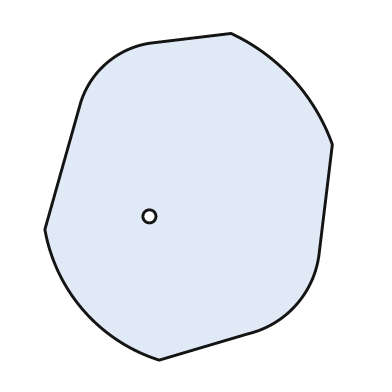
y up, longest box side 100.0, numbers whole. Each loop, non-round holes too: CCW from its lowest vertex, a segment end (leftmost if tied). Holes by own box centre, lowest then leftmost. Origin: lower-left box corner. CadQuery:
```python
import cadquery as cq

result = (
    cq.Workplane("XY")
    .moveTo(35.0, 0.0)
    .lineTo(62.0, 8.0)
    .threePointArc((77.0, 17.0), (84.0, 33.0))
    .lineTo(88.0, 66.0)
    .threePointArc((76.0, 86.0), (57.0, 100.0))
    .lineTo(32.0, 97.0)
    .threePointArc((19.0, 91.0), (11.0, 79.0))
    .lineTo(0.0, 40.0)
    .threePointArc((12.0, 15.0), (35.0, 0.0))
    .close()
    .moveTo(32.0, 44.0)
    .circle(2.0)
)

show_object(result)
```